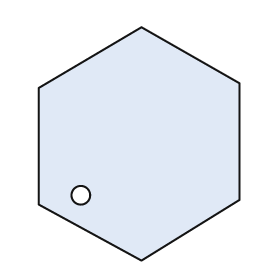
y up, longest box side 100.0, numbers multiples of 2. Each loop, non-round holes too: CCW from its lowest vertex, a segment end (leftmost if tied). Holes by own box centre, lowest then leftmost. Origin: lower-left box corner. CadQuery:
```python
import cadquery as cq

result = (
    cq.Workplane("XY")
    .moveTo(44.0, 0.0)
    .lineTo(86.0, 26.0)
    .lineTo(86.0, 76.0)
    .lineTo(44.0, 100.0)
    .lineTo(0.0, 74.0)
    .lineTo(0.0, 24.0)
    .close()
    .moveTo(18.0, 28.0)
    .circle(4.0)
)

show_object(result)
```